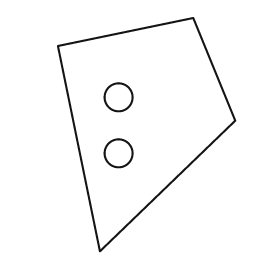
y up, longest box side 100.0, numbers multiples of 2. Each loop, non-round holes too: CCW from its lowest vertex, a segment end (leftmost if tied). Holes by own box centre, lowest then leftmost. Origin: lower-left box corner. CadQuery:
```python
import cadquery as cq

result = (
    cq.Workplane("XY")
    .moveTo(18.0, 0.0)
    .lineTo(76.0, 56.0)
    .lineTo(58.0, 100.0)
    .lineTo(0.0, 88.0)
    .close()
    .moveTo(26.0, 42.0)
    .circle(6.0)
    .moveTo(26.0, 66.0)
    .circle(6.0)
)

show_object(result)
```